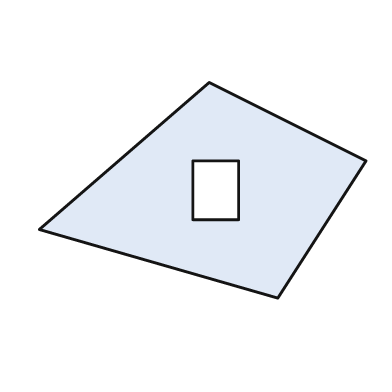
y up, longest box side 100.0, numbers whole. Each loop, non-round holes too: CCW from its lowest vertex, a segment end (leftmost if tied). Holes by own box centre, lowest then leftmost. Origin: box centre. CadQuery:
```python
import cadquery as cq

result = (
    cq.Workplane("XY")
    .moveTo(23.0, -33.0)
    .lineTo(50.0, 9.0)
    .lineTo(2.0, 33.0)
    .lineTo(-50.0, -12.0)
    .close()
    .moveTo(-3.0, -9.0)
    .lineTo(11.0, -9.0)
    .lineTo(11.0, 9.0)
    .lineTo(-3.0, 9.0)
    .close()
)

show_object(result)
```